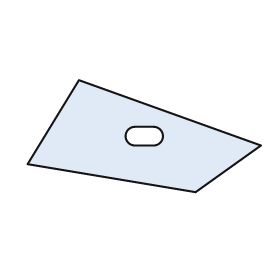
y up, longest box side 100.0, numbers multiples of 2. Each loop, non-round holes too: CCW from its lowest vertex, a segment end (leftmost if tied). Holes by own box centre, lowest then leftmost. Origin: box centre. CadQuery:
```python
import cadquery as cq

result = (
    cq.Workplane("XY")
    .moveTo(22.0, -24.0)
    .lineTo(50.0, -4.0)
    .lineTo(-28.0, 24.0)
    .lineTo(-50.0, -12.0)
    .close()
    .moveTo(-4.0, -4.0)
    .lineTo(4.0, -4.0)
    .threePointArc((8.0, 0.0), (4.0, 4.0))
    .lineTo(-4.0, 4.0)
    .threePointArc((-8.0, 0.0), (-4.0, -4.0))
    .close()
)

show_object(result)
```